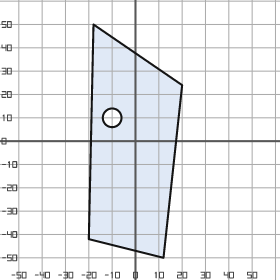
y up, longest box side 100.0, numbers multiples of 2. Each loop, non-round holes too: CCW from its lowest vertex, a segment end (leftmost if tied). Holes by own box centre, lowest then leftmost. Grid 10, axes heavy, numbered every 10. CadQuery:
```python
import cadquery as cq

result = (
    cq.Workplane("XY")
    .moveTo(12.0, -50.0)
    .lineTo(20.0, 24.0)
    .lineTo(-18.0, 50.0)
    .lineTo(-20.0, -42.0)
    .close()
    .moveTo(-10.0, 10.0)
    .circle(4.0)
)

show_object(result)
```